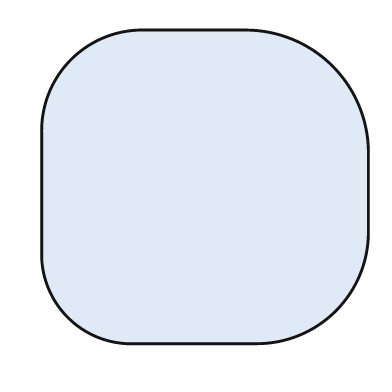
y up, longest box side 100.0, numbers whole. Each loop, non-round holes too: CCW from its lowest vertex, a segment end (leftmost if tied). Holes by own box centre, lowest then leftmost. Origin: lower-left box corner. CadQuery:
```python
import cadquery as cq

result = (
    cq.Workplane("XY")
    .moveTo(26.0, 0.0)
    .lineTo(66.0, 0.0)
    .threePointArc((90.0, 10.0), (100.0, 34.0))
    .lineTo(100.0, 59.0)
    .threePointArc((89.0, 85.0), (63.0, 96.0))
    .lineTo(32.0, 96.0)
    .threePointArc((9.0, 87.0), (0.0, 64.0))
    .lineTo(0.0, 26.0)
    .threePointArc((8.0, 8.0), (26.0, 0.0))
    .close()
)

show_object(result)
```